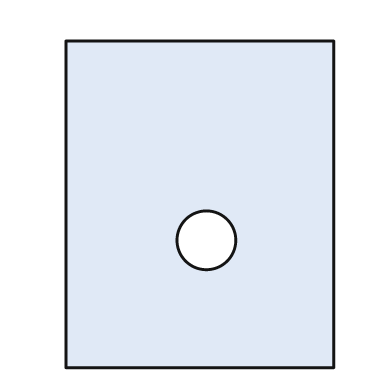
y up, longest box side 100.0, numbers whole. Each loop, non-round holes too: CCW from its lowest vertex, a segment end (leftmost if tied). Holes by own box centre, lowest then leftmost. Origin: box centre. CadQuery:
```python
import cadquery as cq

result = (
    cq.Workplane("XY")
    .moveTo(-41.0, -50.0)
    .lineTo(41.0, -50.0)
    .lineTo(41.0, 50.0)
    .lineTo(-41.0, 50.0)
    .close()
    .moveTo(2.0, -11.0)
    .circle(9.0)
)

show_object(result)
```